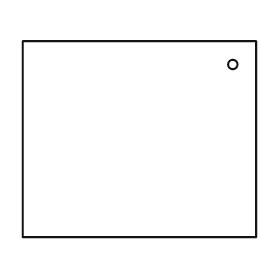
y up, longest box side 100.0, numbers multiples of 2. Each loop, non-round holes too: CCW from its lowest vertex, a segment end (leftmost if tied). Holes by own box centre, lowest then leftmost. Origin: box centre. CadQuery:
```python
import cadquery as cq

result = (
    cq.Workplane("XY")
    .moveTo(-50.0, -42.0)
    .lineTo(50.0, -42.0)
    .lineTo(50.0, 42.0)
    .lineTo(-50.0, 42.0)
    .close()
    .moveTo(40.0, 32.0)
    .circle(2.0)
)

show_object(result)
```